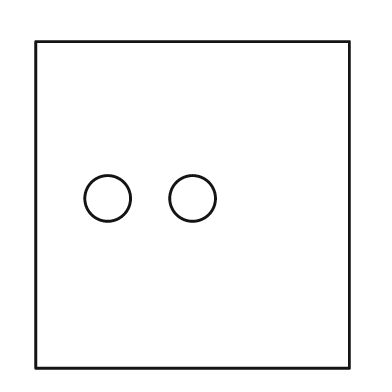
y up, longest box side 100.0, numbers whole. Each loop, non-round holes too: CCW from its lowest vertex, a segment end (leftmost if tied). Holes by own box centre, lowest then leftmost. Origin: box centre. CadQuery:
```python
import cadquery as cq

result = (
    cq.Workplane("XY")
    .moveTo(-48.0, -50.0)
    .lineTo(48.0, -50.0)
    .lineTo(48.0, 50.0)
    .lineTo(-48.0, 50.0)
    .close()
    .moveTo(-26.0, 2.0)
    .circle(7.0)
    .moveTo(0.0, 2.0)
    .circle(7.0)
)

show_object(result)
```